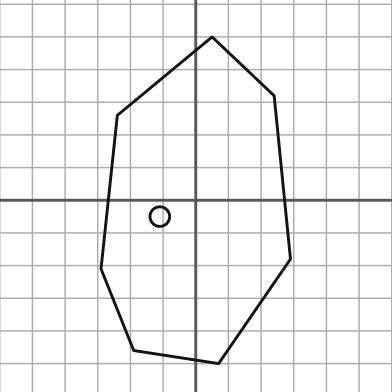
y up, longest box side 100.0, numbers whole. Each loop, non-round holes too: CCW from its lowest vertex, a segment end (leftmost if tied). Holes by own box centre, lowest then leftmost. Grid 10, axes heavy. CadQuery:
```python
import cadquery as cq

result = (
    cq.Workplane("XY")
    .moveTo(7.0, -50.0)
    .lineTo(29.0, -18.0)
    .lineTo(24.0, 32.0)
    .lineTo(5.0, 50.0)
    .lineTo(-24.0, 26.0)
    .lineTo(-29.0, -21.0)
    .lineTo(-19.0, -46.0)
    .close()
    .moveTo(-11.0, -5.0)
    .circle(3.0)
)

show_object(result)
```